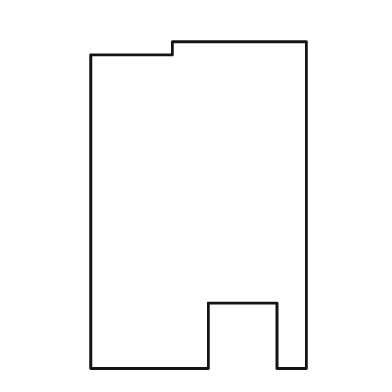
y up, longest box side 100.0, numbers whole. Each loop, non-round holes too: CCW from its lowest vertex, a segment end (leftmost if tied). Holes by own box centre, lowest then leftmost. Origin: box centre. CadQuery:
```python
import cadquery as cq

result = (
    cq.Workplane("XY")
    .moveTo(-33.0, -50.0)
    .lineTo(3.0, -50.0)
    .lineTo(3.0, -30.0)
    .lineTo(24.0, -30.0)
    .lineTo(24.0, -50.0)
    .lineTo(33.0, -50.0)
    .lineTo(33.0, 50.0)
    .lineTo(-8.0, 50.0)
    .lineTo(-8.0, 46.0)
    .lineTo(-33.0, 46.0)
    .close()
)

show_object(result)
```